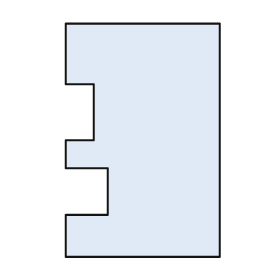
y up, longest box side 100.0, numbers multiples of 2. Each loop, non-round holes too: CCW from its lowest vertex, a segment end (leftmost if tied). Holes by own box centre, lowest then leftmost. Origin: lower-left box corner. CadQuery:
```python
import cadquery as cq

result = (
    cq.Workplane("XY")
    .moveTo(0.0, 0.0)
    .lineTo(66.0, 0.0)
    .lineTo(66.0, 100.0)
    .lineTo(0.0, 100.0)
    .lineTo(0.0, 74.0)
    .lineTo(12.0, 74.0)
    .lineTo(12.0, 50.0)
    .lineTo(0.0, 50.0)
    .lineTo(0.0, 38.0)
    .lineTo(18.0, 38.0)
    .lineTo(18.0, 18.0)
    .lineTo(0.0, 18.0)
    .close()
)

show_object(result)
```